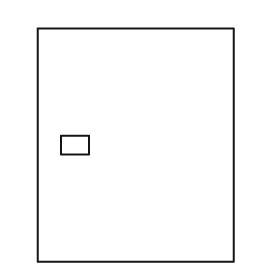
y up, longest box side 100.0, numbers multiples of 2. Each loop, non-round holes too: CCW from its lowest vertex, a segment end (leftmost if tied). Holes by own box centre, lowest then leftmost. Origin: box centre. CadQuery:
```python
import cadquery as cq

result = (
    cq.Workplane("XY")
    .moveTo(-42.0, -50.0)
    .lineTo(42.0, -50.0)
    .lineTo(42.0, 50.0)
    .lineTo(-42.0, 50.0)
    .close()
    .moveTo(-32.0, -4.0)
    .lineTo(-20.0, -4.0)
    .lineTo(-20.0, 4.0)
    .lineTo(-32.0, 4.0)
    .close()
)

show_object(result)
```